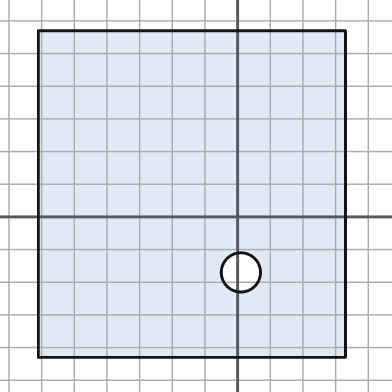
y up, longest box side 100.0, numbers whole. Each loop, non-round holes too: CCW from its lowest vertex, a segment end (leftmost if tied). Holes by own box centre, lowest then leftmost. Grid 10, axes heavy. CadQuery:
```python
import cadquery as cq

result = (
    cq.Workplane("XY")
    .moveTo(-61.0, -43.0)
    .lineTo(33.0, -43.0)
    .lineTo(33.0, 57.0)
    .lineTo(-61.0, 57.0)
    .close()
    .moveTo(1.0, -17.0)
    .circle(6.0)
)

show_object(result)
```